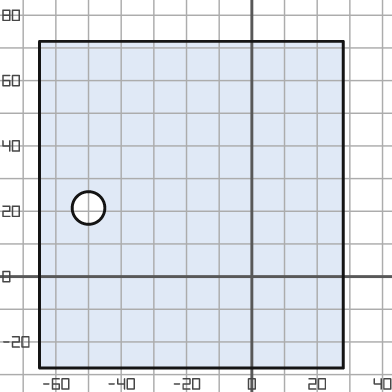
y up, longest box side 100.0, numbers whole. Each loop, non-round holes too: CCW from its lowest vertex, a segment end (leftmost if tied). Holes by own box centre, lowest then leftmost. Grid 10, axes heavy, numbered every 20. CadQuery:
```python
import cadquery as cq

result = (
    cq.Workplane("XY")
    .moveTo(-65.0, -28.0)
    .lineTo(28.0, -28.0)
    .lineTo(28.0, 72.0)
    .lineTo(-65.0, 72.0)
    .close()
    .moveTo(-50.0, 21.0)
    .circle(5.0)
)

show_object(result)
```